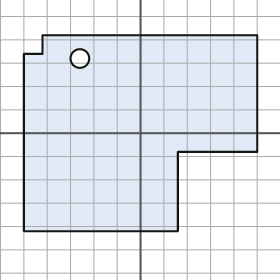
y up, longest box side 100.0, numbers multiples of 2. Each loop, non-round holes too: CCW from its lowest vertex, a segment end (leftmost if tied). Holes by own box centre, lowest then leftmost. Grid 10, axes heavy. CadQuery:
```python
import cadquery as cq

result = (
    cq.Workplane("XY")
    .moveTo(-50.0, -42.0)
    .lineTo(16.0, -42.0)
    .lineTo(16.0, -8.0)
    .lineTo(50.0, -8.0)
    .lineTo(50.0, 42.0)
    .lineTo(-42.0, 42.0)
    .lineTo(-42.0, 34.0)
    .lineTo(-50.0, 34.0)
    .close()
    .moveTo(-26.0, 32.0)
    .circle(4.0)
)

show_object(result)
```